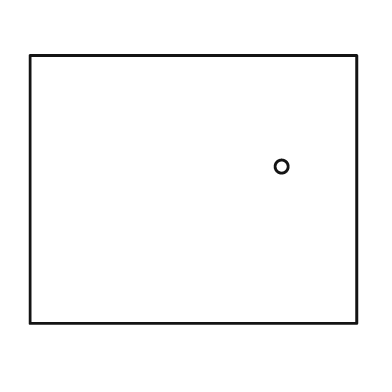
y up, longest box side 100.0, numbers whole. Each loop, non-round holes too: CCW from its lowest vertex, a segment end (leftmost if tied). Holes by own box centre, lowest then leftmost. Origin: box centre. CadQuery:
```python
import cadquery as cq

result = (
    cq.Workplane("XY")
    .moveTo(-50.0, -41.0)
    .lineTo(50.0, -41.0)
    .lineTo(50.0, 41.0)
    .lineTo(-50.0, 41.0)
    .close()
    .moveTo(27.0, 7.0)
    .circle(2.0)
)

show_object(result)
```